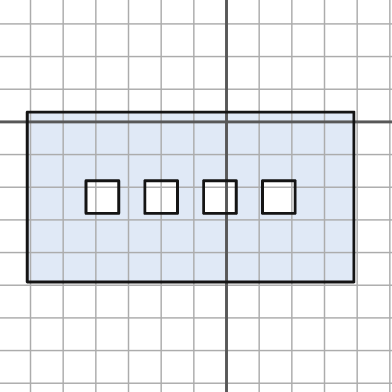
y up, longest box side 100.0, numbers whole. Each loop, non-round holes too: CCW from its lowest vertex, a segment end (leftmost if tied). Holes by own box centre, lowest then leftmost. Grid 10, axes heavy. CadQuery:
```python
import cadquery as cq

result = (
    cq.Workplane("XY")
    .moveTo(-61.0, -49.0)
    .lineTo(39.0, -49.0)
    .lineTo(39.0, 3.0)
    .lineTo(-61.0, 3.0)
    .close()
    .moveTo(-43.0, -28.0)
    .lineTo(-33.0, -28.0)
    .lineTo(-33.0, -18.0)
    .lineTo(-43.0, -18.0)
    .close()
    .moveTo(-25.0, -28.0)
    .lineTo(-15.0, -28.0)
    .lineTo(-15.0, -18.0)
    .lineTo(-25.0, -18.0)
    .close()
    .moveTo(-7.0, -28.0)
    .lineTo(3.0, -28.0)
    .lineTo(3.0, -18.0)
    .lineTo(-7.0, -18.0)
    .close()
    .moveTo(11.0, -28.0)
    .lineTo(21.0, -28.0)
    .lineTo(21.0, -18.0)
    .lineTo(11.0, -18.0)
    .close()
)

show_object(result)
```